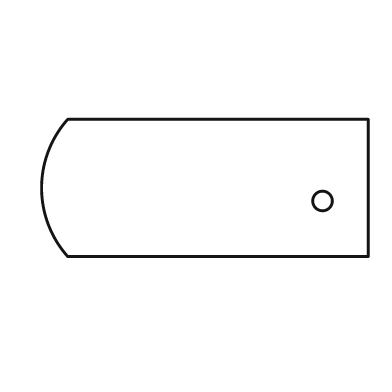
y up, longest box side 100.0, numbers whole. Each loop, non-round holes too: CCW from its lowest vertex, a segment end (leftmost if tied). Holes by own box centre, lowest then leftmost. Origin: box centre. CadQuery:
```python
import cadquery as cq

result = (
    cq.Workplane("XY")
    .moveTo(-42.0, -21.0)
    .lineTo(50.0, -21.0)
    .lineTo(50.0, 21.0)
    .lineTo(-42.0, 21.0)
    .threePointArc((-50.0, 0.0), (-42.0, -21.0))
    .close()
    .moveTo(36.0, -4.0)
    .circle(3.0)
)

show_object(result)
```